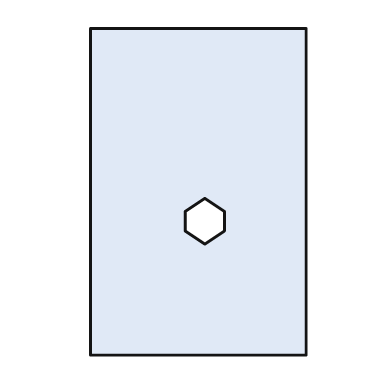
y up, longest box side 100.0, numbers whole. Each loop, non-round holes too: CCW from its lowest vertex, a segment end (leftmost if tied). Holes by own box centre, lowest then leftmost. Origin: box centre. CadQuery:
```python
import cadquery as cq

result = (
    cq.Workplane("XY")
    .moveTo(-33.0, -50.0)
    .lineTo(33.0, -50.0)
    .lineTo(33.0, 50.0)
    .lineTo(-33.0, 50.0)
    .close()
    .moveTo(2.0, -16.0)
    .lineTo(8.0, -12.0)
    .lineTo(8.0, -6.0)
    .lineTo(2.0, -2.0)
    .lineTo(-4.0, -6.0)
    .lineTo(-4.0, -12.0)
    .close()
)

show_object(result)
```